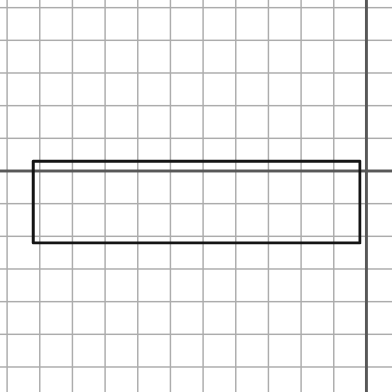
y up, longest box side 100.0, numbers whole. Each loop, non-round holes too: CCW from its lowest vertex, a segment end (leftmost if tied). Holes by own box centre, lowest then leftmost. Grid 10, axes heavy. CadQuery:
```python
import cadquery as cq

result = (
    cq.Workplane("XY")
    .moveTo(-102.0, -22.0)
    .lineTo(-2.0, -22.0)
    .lineTo(-2.0, 3.0)
    .lineTo(-102.0, 3.0)
    .close()
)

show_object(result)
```